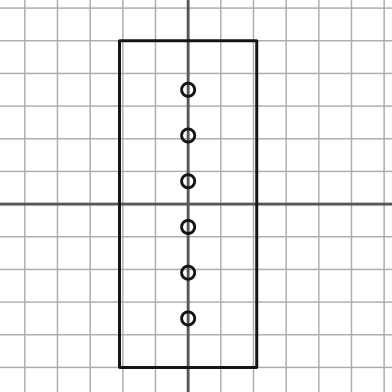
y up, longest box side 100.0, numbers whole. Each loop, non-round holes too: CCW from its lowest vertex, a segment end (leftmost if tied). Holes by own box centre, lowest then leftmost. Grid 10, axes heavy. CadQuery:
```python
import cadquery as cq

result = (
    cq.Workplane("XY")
    .moveTo(-21.0, -50.0)
    .lineTo(21.0, -50.0)
    .lineTo(21.0, 50.0)
    .lineTo(-21.0, 50.0)
    .close()
    .moveTo(0.0, -35.0)
    .circle(2.0)
    .moveTo(0.0, -21.0)
    .circle(2.0)
    .moveTo(0.0, -7.0)
    .circle(2.0)
    .moveTo(0.0, 7.0)
    .circle(2.0)
    .moveTo(0.0, 21.0)
    .circle(2.0)
    .moveTo(0.0, 35.0)
    .circle(2.0)
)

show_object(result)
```